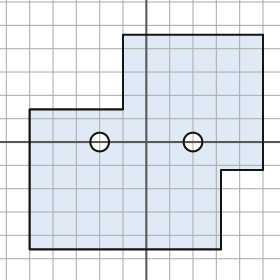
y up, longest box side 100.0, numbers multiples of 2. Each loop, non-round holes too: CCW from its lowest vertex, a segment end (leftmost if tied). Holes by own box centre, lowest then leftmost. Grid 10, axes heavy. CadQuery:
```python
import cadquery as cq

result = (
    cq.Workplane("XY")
    .moveTo(-50.0, -46.0)
    .lineTo(32.0, -46.0)
    .lineTo(32.0, -12.0)
    .lineTo(50.0, -12.0)
    .lineTo(50.0, 46.0)
    .lineTo(-10.0, 46.0)
    .lineTo(-10.0, 14.0)
    .lineTo(-50.0, 14.0)
    .close()
    .moveTo(-20.0, 0.0)
    .circle(4.0)
    .moveTo(20.0, 0.0)
    .circle(4.0)
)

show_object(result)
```